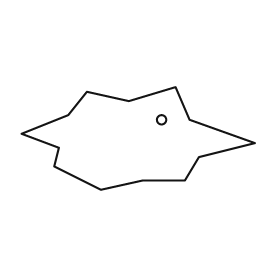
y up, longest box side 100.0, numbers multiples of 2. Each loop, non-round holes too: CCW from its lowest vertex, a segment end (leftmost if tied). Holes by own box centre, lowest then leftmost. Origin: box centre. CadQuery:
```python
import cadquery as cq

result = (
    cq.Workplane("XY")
    .moveTo(-16.0, -22.0)
    .lineTo(2.0, -18.0)
    .lineTo(20.0, -18.0)
    .lineTo(26.0, -8.0)
    .lineTo(50.0, -2.0)
    .lineTo(22.0, 8.0)
    .lineTo(16.0, 22.0)
    .lineTo(-4.0, 16.0)
    .lineTo(-22.0, 20.0)
    .lineTo(-30.0, 10.0)
    .lineTo(-50.0, 2.0)
    .lineTo(-34.0, -4.0)
    .lineTo(-36.0, -12.0)
    .close()
    .moveTo(10.0, 8.0)
    .circle(2.0)
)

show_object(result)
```